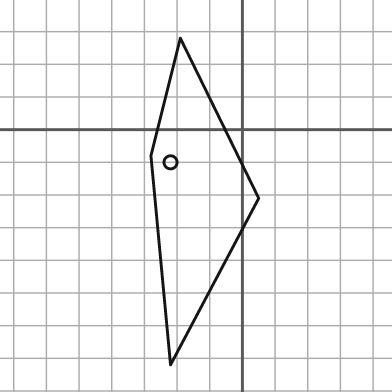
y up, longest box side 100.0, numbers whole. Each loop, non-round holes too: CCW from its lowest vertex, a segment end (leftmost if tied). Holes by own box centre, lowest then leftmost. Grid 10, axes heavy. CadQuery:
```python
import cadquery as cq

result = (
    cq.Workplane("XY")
    .moveTo(-22.0, -72.0)
    .lineTo(5.0, -21.0)
    .lineTo(-19.0, 28.0)
    .lineTo(-28.0, -8.0)
    .close()
    .moveTo(-22.0, -10.0)
    .circle(2.0)
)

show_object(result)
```